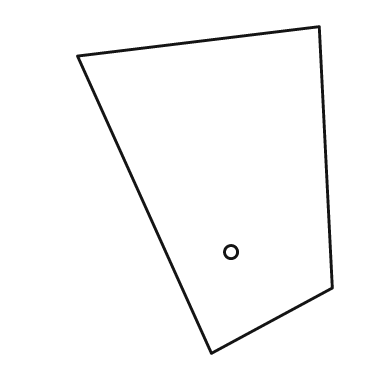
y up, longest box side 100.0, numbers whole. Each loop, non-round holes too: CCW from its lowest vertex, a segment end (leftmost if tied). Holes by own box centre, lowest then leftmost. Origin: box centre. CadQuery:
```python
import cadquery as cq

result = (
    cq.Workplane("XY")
    .moveTo(2.0, -50.0)
    .lineTo(39.0, -30.0)
    .lineTo(35.0, 50.0)
    .lineTo(-39.0, 41.0)
    .close()
    .moveTo(8.0, -19.0)
    .circle(2.0)
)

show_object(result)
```